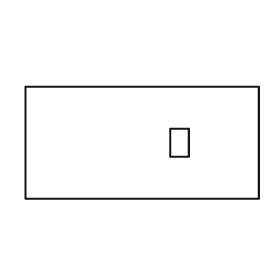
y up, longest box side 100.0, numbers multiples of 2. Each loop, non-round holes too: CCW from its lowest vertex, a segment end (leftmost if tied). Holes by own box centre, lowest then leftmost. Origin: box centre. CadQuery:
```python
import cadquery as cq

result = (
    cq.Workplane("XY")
    .moveTo(-50.0, -24.0)
    .lineTo(50.0, -24.0)
    .lineTo(50.0, 24.0)
    .lineTo(-50.0, 24.0)
    .close()
    .moveTo(12.0, -6.0)
    .lineTo(20.0, -6.0)
    .lineTo(20.0, 6.0)
    .lineTo(12.0, 6.0)
    .close()
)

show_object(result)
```